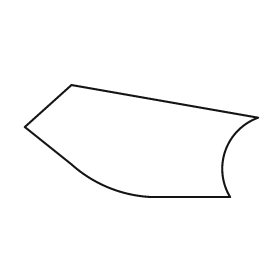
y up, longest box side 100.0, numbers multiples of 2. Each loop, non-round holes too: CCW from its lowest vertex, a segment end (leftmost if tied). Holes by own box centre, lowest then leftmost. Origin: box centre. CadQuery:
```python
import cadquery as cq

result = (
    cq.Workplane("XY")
    .moveTo(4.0, -24.0)
    .lineTo(38.0, -24.0)
    .threePointArc((36.0, -4.0), (50.0, 10.0))
    .lineTo(-30.0, 24.0)
    .lineTo(-50.0, 6.0)
    .lineTo(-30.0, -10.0)
    .threePointArc((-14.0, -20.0), (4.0, -24.0))
    .close()
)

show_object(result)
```